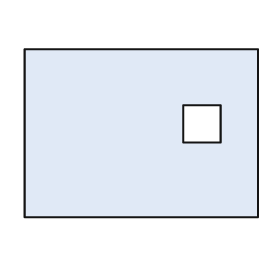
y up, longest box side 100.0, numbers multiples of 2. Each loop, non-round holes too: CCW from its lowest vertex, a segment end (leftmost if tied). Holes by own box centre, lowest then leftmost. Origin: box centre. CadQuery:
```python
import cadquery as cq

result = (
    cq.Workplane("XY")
    .moveTo(-50.0, -36.0)
    .lineTo(50.0, -36.0)
    .lineTo(50.0, 36.0)
    .lineTo(-50.0, 36.0)
    .close()
    .moveTo(18.0, -4.0)
    .lineTo(34.0, -4.0)
    .lineTo(34.0, 12.0)
    .lineTo(18.0, 12.0)
    .close()
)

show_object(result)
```